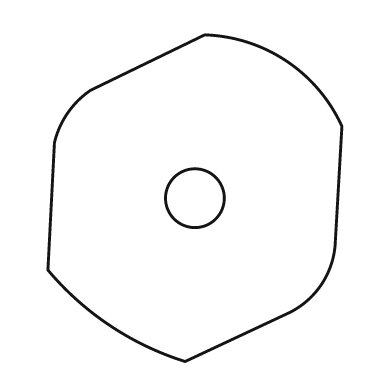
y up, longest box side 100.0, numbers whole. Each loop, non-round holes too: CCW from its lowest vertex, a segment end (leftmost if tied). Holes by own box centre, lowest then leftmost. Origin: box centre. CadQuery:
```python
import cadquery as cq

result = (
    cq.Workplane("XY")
    .moveTo(-3.0, -50.0)
    .lineTo(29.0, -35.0)
    .threePointArc((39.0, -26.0), (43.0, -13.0))
    .lineTo(45.0, 22.0)
    .threePointArc((28.0, 42.0), (3.0, 50.0))
    .lineTo(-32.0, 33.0)
    .threePointArc((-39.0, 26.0), (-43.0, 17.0))
    .lineTo(-45.0, -22.0)
    .threePointArc((-26.0, -39.0), (-3.0, -50.0))
    .close()
    .moveTo(0.0, 0.0)
    .circle(9.0)
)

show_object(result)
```